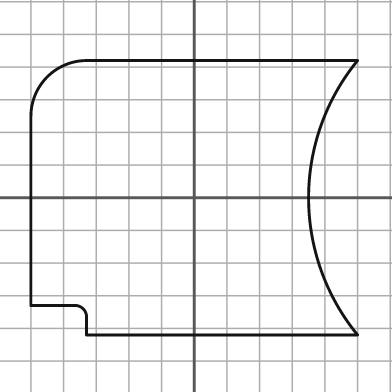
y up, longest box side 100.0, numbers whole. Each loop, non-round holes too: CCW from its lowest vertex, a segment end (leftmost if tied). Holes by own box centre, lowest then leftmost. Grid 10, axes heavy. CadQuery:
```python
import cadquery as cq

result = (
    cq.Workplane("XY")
    .moveTo(-33.0, -42.0)
    .lineTo(50.0, -42.0)
    .threePointArc((35.0, 0.0), (50.0, 42.0))
    .lineTo(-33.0, 42.0)
    .threePointArc((-45.0, 37.0), (-50.0, 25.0))
    .lineTo(-50.0, -33.0)
    .lineTo(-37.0, -33.0)
    .threePointArc((-34.0, -34.0), (-33.0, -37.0))
    .close()
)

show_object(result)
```